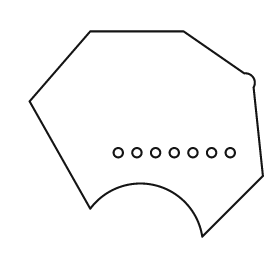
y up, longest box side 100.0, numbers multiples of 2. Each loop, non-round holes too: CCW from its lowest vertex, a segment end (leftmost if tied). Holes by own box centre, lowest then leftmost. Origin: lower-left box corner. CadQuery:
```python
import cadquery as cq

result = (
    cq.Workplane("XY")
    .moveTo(74.0, 0.0)
    .lineTo(100.0, 26.0)
    .lineTo(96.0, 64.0)
    .threePointArc((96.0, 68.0), (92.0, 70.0))
    .lineTo(66.0, 88.0)
    .lineTo(26.0, 88.0)
    .lineTo(0.0, 58.0)
    .lineTo(26.0, 12.0)
    .threePointArc((54.0, 22.0), (74.0, 0.0))
    .close()
    .moveTo(38.0, 36.0)
    .circle(2.0)
    .moveTo(46.0, 36.0)
    .circle(2.0)
    .moveTo(54.0, 36.0)
    .circle(2.0)
    .moveTo(62.0, 36.0)
    .circle(2.0)
    .moveTo(70.0, 36.0)
    .circle(2.0)
    .moveTo(78.0, 36.0)
    .circle(2.0)
    .moveTo(86.0, 36.0)
    .circle(2.0)
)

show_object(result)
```